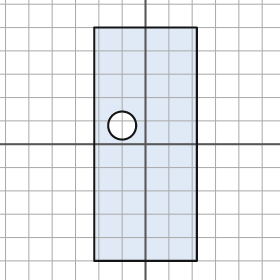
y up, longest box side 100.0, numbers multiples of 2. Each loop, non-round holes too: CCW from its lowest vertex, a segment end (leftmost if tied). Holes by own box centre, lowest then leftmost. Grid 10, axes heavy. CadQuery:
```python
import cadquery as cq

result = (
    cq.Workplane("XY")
    .moveTo(-22.0, -50.0)
    .lineTo(22.0, -50.0)
    .lineTo(22.0, 50.0)
    .lineTo(-22.0, 50.0)
    .close()
    .moveTo(-10.0, 8.0)
    .circle(6.0)
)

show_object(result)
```